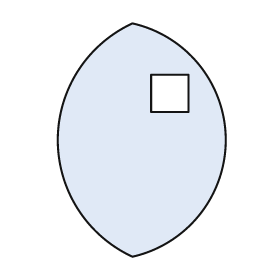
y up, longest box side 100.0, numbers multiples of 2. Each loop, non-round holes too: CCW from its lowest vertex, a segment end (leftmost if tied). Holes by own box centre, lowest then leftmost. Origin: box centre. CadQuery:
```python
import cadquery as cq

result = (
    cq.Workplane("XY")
    .moveTo(-4.0, -50.0)
    .threePointArc((36.0, 0.0), (-4.0, 50.0))
    .threePointArc((-36.0, 0.0), (-4.0, -50.0))
    .close()
    .moveTo(4.0, 12.0)
    .lineTo(20.0, 12.0)
    .lineTo(20.0, 28.0)
    .lineTo(4.0, 28.0)
    .close()
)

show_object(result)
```